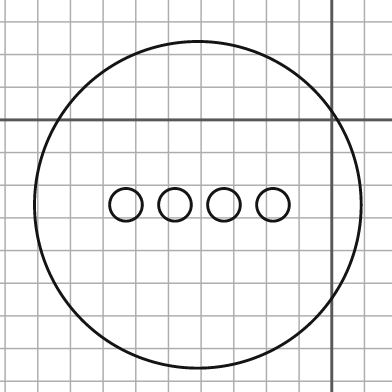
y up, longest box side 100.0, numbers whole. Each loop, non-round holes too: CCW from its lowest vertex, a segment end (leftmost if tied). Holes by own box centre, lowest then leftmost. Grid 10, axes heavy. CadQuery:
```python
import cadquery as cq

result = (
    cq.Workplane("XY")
    .moveTo(-41.0, -26.0)
    .circle(50.0)
    .moveTo(-63.0, -26.0)
    .circle(5.0)
    .moveTo(-48.0, -26.0)
    .circle(5.0)
    .moveTo(-33.0, -26.0)
    .circle(5.0)
    .moveTo(-18.0, -26.0)
    .circle(5.0)
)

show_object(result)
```